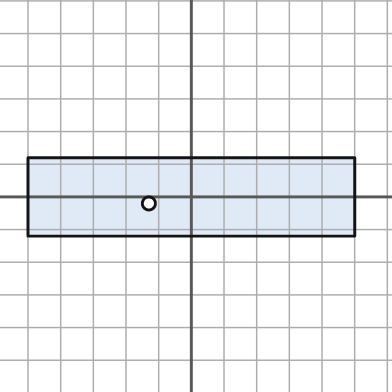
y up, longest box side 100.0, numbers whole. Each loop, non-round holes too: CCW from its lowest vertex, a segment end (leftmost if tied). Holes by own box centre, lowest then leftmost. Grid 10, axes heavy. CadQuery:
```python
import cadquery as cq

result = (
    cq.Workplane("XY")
    .moveTo(-50.0, -12.0)
    .lineTo(50.0, -12.0)
    .lineTo(50.0, 12.0)
    .lineTo(-50.0, 12.0)
    .close()
    .moveTo(-13.0, -2.0)
    .circle(2.0)
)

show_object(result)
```